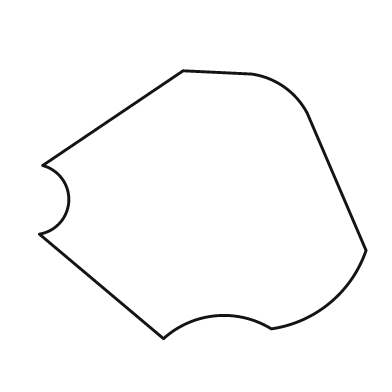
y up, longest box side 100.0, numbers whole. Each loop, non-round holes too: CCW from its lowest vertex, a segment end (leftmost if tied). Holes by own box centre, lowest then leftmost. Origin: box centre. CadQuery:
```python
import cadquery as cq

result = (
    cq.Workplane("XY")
    .moveTo(-12.0, -41.0)
    .threePointArc((4.0, -34.0), (21.0, -38.0))
    .threePointArc((39.0, -30.0), (50.0, -14.0))
    .lineTo(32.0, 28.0)
    .threePointArc((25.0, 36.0), (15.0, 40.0))
    .lineTo(-6.0, 41.0)
    .lineTo(-49.0, 12.0)
    .threePointArc((-41.0, 1.0), (-50.0, -9.0))
    .close()
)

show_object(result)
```